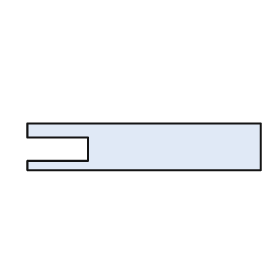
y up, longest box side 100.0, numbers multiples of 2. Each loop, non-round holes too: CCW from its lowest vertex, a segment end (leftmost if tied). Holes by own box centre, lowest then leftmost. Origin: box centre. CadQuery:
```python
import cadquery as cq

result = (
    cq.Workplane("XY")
    .moveTo(-50.0, -10.0)
    .lineTo(50.0, -10.0)
    .lineTo(50.0, 10.0)
    .lineTo(-50.0, 10.0)
    .lineTo(-50.0, 4.0)
    .lineTo(-24.0, 4.0)
    .lineTo(-24.0, -6.0)
    .lineTo(-50.0, -6.0)
    .close()
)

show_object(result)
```